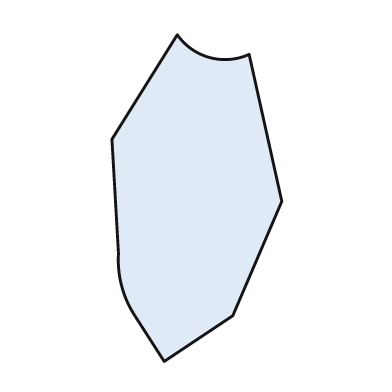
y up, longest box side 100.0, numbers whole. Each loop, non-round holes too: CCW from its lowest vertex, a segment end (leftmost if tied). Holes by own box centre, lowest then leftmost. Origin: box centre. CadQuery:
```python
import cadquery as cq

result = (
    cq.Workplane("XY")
    .moveTo(-10.0, -50.0)
    .lineTo(11.0, -36.0)
    .lineTo(26.0, -1.0)
    .lineTo(16.0, 44.0)
    .threePointArc((4.0, 43.0), (-6.0, 50.0))
    .lineTo(-26.0, 18.0)
    .lineTo(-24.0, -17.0)
    .threePointArc((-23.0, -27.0), (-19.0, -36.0))
    .close()
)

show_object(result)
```